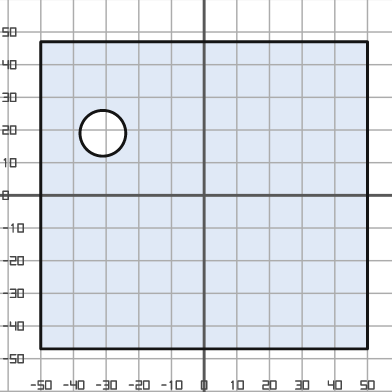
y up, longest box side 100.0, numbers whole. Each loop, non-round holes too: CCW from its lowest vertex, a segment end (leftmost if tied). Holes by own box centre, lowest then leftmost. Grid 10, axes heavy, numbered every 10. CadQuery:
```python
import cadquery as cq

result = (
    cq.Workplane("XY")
    .moveTo(-50.0, -47.0)
    .lineTo(50.0, -47.0)
    .lineTo(50.0, 47.0)
    .lineTo(-50.0, 47.0)
    .close()
    .moveTo(-31.0, 19.0)
    .circle(7.0)
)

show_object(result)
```